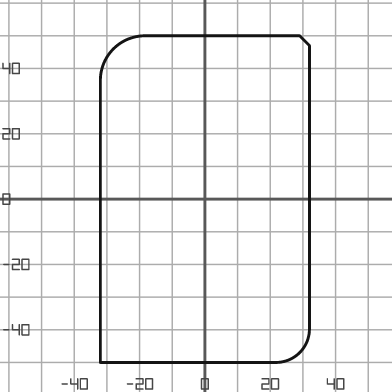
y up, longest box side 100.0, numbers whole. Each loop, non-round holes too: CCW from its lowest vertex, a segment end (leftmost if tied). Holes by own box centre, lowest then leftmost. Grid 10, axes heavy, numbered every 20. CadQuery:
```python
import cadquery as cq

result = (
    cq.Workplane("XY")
    .moveTo(-32.0, -50.0)
    .lineTo(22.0, -50.0)
    .threePointArc((29.0, -47.0), (32.0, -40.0))
    .lineTo(32.0, 47.0)
    .lineTo(29.0, 50.0)
    .lineTo(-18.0, 50.0)
    .threePointArc((-28.0, 46.0), (-32.0, 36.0))
    .close()
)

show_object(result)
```